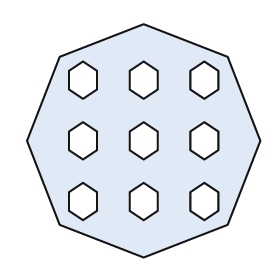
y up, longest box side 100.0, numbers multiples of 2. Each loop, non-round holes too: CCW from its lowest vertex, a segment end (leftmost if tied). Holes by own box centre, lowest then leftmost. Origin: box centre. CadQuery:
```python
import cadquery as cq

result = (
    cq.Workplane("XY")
    .moveTo(0.0, -50.0)
    .lineTo(36.0, -36.0)
    .lineTo(50.0, 0.0)
    .lineTo(36.0, 36.0)
    .lineTo(0.0, 50.0)
    .lineTo(-36.0, 36.0)
    .lineTo(-50.0, 0.0)
    .lineTo(-36.0, -36.0)
    .close()
    .moveTo(-26.0, -34.0)
    .lineTo(-20.0, -30.0)
    .lineTo(-20.0, -22.0)
    .lineTo(-26.0, -18.0)
    .lineTo(-32.0, -22.0)
    .lineTo(-32.0, -30.0)
    .close()
    .moveTo(0.0, -34.0)
    .lineTo(6.0, -30.0)
    .lineTo(6.0, -22.0)
    .lineTo(0.0, -18.0)
    .lineTo(-6.0, -22.0)
    .lineTo(-6.0, -30.0)
    .close()
    .moveTo(26.0, -34.0)
    .lineTo(32.0, -30.0)
    .lineTo(32.0, -22.0)
    .lineTo(26.0, -18.0)
    .lineTo(20.0, -22.0)
    .lineTo(20.0, -30.0)
    .close()
    .moveTo(-26.0, -8.0)
    .lineTo(-20.0, -4.0)
    .lineTo(-20.0, 4.0)
    .lineTo(-26.0, 8.0)
    .lineTo(-32.0, 4.0)
    .lineTo(-32.0, -4.0)
    .close()
    .moveTo(0.0, -8.0)
    .lineTo(6.0, -4.0)
    .lineTo(6.0, 4.0)
    .lineTo(0.0, 8.0)
    .lineTo(-6.0, 4.0)
    .lineTo(-6.0, -4.0)
    .close()
    .moveTo(26.0, -8.0)
    .lineTo(32.0, -4.0)
    .lineTo(32.0, 4.0)
    .lineTo(26.0, 8.0)
    .lineTo(20.0, 4.0)
    .lineTo(20.0, -4.0)
    .close()
    .moveTo(-26.0, 18.0)
    .lineTo(-20.0, 22.0)
    .lineTo(-20.0, 30.0)
    .lineTo(-26.0, 34.0)
    .lineTo(-32.0, 30.0)
    .lineTo(-32.0, 22.0)
    .close()
    .moveTo(0.0, 18.0)
    .lineTo(6.0, 22.0)
    .lineTo(6.0, 30.0)
    .lineTo(0.0, 34.0)
    .lineTo(-6.0, 30.0)
    .lineTo(-6.0, 22.0)
    .close()
    .moveTo(26.0, 18.0)
    .lineTo(32.0, 22.0)
    .lineTo(32.0, 30.0)
    .lineTo(26.0, 34.0)
    .lineTo(20.0, 30.0)
    .lineTo(20.0, 22.0)
    .close()
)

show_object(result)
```